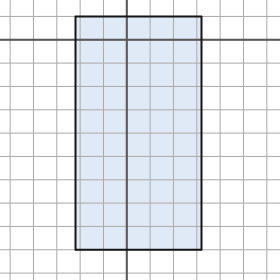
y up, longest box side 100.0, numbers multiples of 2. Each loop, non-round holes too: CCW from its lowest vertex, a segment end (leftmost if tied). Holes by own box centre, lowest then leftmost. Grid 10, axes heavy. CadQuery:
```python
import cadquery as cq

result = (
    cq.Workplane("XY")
    .moveTo(-22.0, -90.0)
    .lineTo(32.0, -90.0)
    .lineTo(32.0, 10.0)
    .lineTo(-22.0, 10.0)
    .close()
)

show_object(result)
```